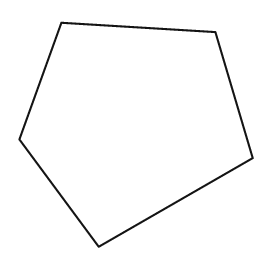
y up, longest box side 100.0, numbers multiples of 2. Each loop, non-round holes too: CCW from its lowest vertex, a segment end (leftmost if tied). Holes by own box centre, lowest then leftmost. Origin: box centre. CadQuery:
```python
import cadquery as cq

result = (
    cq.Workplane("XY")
    .moveTo(-16.0, -48.0)
    .lineTo(50.0, -10.0)
    .lineTo(34.0, 44.0)
    .lineTo(-32.0, 48.0)
    .lineTo(-50.0, -2.0)
    .close()
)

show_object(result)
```